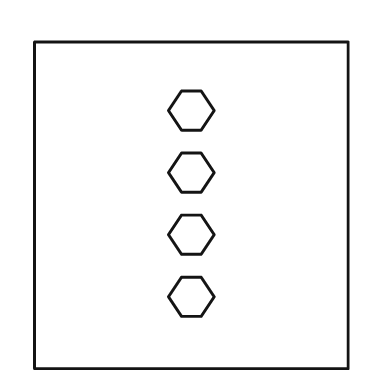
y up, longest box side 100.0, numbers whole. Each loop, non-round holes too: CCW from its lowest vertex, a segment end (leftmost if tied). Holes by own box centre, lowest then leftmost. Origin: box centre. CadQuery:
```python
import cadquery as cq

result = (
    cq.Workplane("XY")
    .moveTo(-48.0, -50.0)
    .lineTo(48.0, -50.0)
    .lineTo(48.0, 50.0)
    .lineTo(-48.0, 50.0)
    .close()
    .moveTo(-3.0, -34.0)
    .lineTo(3.0, -34.0)
    .lineTo(7.0, -28.0)
    .lineTo(3.0, -22.0)
    .lineTo(-3.0, -22.0)
    .lineTo(-7.0, -28.0)
    .close()
    .moveTo(-3.0, -15.0)
    .lineTo(3.0, -15.0)
    .lineTo(7.0, -9.0)
    .lineTo(3.0, -3.0)
    .lineTo(-3.0, -3.0)
    .lineTo(-7.0, -9.0)
    .close()
    .moveTo(-3.0, 4.0)
    .lineTo(3.0, 4.0)
    .lineTo(7.0, 10.0)
    .lineTo(3.0, 16.0)
    .lineTo(-3.0, 16.0)
    .lineTo(-7.0, 10.0)
    .close()
    .moveTo(-3.0, 23.0)
    .lineTo(3.0, 23.0)
    .lineTo(7.0, 29.0)
    .lineTo(3.0, 35.0)
    .lineTo(-3.0, 35.0)
    .lineTo(-7.0, 29.0)
    .close()
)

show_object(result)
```